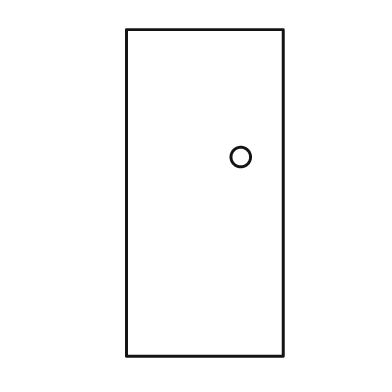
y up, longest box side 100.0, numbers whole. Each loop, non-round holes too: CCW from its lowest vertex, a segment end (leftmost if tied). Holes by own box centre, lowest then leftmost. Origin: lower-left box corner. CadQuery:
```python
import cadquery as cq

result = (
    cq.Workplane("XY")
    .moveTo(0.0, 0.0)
    .lineTo(48.0, 0.0)
    .lineTo(48.0, 100.0)
    .lineTo(0.0, 100.0)
    .close()
    .moveTo(35.0, 61.0)
    .circle(3.0)
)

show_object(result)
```